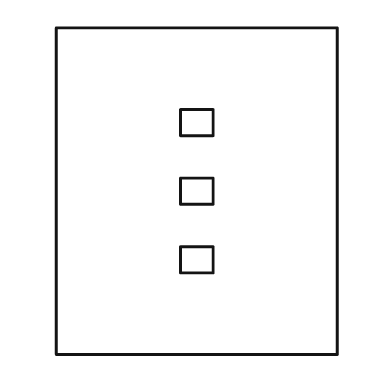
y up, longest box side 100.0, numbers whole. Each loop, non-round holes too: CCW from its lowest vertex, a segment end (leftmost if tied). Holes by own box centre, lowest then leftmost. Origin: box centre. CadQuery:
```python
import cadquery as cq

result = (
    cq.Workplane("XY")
    .moveTo(-43.0, -50.0)
    .lineTo(43.0, -50.0)
    .lineTo(43.0, 50.0)
    .lineTo(-43.0, 50.0)
    .close()
    .moveTo(-5.0, -25.0)
    .lineTo(5.0, -25.0)
    .lineTo(5.0, -17.0)
    .lineTo(-5.0, -17.0)
    .close()
    .moveTo(-5.0, -4.0)
    .lineTo(5.0, -4.0)
    .lineTo(5.0, 4.0)
    .lineTo(-5.0, 4.0)
    .close()
    .moveTo(-5.0, 17.0)
    .lineTo(5.0, 17.0)
    .lineTo(5.0, 25.0)
    .lineTo(-5.0, 25.0)
    .close()
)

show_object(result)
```